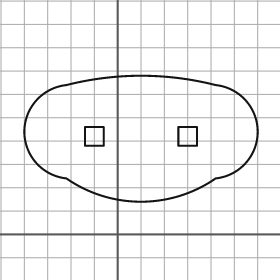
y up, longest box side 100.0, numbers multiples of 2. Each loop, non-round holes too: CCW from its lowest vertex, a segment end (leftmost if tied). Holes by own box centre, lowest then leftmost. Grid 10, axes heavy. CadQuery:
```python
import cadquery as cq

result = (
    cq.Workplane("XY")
    .moveTo(-22.0, 24.0)
    .threePointArc((10.0, 14.0), (42.0, 24.0))
    .threePointArc((60.0, 44.0), (42.0, 64.0))
    .threePointArc((10.0, 68.0), (-22.0, 64.0))
    .threePointArc((-40.0, 44.0), (-22.0, 24.0))
    .close()
    .moveTo(-14.0, 38.0)
    .lineTo(-6.0, 38.0)
    .lineTo(-6.0, 46.0)
    .lineTo(-14.0, 46.0)
    .close()
    .moveTo(26.0, 38.0)
    .lineTo(34.0, 38.0)
    .lineTo(34.0, 46.0)
    .lineTo(26.0, 46.0)
    .close()
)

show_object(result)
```